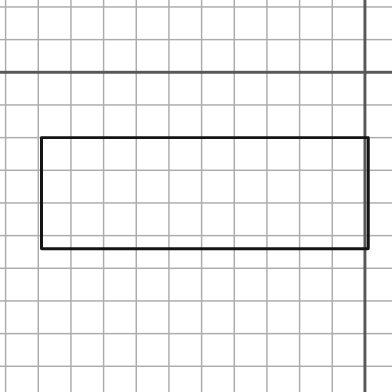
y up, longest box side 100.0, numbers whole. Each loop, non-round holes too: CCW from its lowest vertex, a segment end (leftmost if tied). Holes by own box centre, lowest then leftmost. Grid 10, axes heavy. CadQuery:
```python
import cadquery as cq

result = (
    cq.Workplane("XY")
    .moveTo(-99.0, -54.0)
    .lineTo(1.0, -54.0)
    .lineTo(1.0, -20.0)
    .lineTo(-99.0, -20.0)
    .close()
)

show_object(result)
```